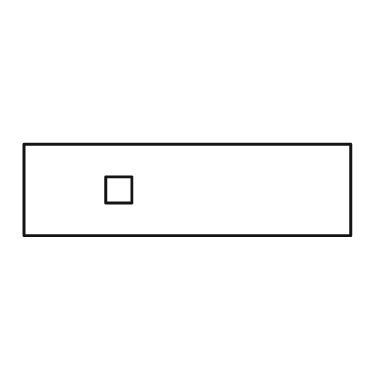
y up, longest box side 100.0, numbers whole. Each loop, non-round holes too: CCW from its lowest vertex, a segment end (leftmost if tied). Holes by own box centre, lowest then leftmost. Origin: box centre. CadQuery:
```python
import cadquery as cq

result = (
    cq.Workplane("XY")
    .moveTo(-50.0, -14.0)
    .lineTo(50.0, -14.0)
    .lineTo(50.0, 14.0)
    .lineTo(-50.0, 14.0)
    .close()
    .moveTo(-25.0, -4.0)
    .lineTo(-17.0, -4.0)
    .lineTo(-17.0, 4.0)
    .lineTo(-25.0, 4.0)
    .close()
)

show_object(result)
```